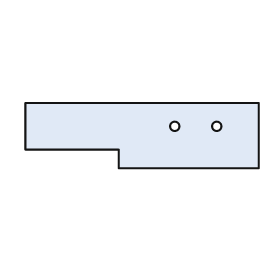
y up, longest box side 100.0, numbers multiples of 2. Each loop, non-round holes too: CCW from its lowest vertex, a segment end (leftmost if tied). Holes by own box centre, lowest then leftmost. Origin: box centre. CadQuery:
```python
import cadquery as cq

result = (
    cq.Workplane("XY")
    .moveTo(-10.0, -14.0)
    .lineTo(50.0, -14.0)
    .lineTo(50.0, 14.0)
    .lineTo(-50.0, 14.0)
    .lineTo(-50.0, -6.0)
    .lineTo(-10.0, -6.0)
    .close()
    .moveTo(14.0, 4.0)
    .circle(2.0)
    .moveTo(32.0, 4.0)
    .circle(2.0)
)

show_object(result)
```